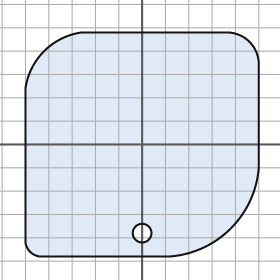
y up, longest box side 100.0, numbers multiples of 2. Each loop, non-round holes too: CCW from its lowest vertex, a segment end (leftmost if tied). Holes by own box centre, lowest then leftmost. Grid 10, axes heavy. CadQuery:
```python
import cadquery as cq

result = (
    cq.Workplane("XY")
    .moveTo(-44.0, -48.0)
    .lineTo(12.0, -48.0)
    .threePointArc((38.0, -36.0), (50.0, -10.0))
    .lineTo(50.0, 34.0)
    .threePointArc((46.0, 44.0), (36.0, 48.0))
    .lineTo(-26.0, 48.0)
    .threePointArc((-42.0, 40.0), (-50.0, 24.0))
    .lineTo(-50.0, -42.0)
    .threePointArc((-48.0, -46.0), (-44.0, -48.0))
    .close()
    .moveTo(0.0, -38.0)
    .circle(4.0)
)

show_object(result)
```